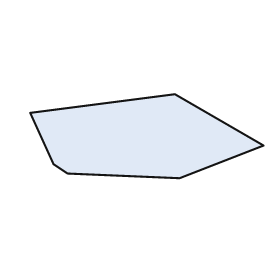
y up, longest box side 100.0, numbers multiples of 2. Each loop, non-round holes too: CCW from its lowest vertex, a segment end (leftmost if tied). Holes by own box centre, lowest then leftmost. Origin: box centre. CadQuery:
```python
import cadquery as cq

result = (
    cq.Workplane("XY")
    .moveTo(14.0, -18.0)
    .lineTo(50.0, -4.0)
    .lineTo(12.0, 18.0)
    .lineTo(-50.0, 10.0)
    .lineTo(-40.0, -12.0)
    .lineTo(-34.0, -16.0)
    .close()
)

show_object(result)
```